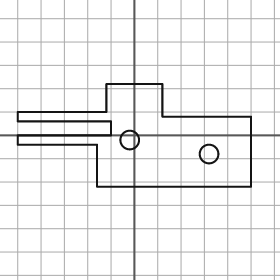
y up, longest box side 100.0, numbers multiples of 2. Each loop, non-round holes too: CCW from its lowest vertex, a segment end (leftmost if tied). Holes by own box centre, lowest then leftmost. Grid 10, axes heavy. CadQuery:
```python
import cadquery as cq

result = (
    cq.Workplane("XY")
    .moveTo(-16.0, -22.0)
    .lineTo(50.0, -22.0)
    .lineTo(50.0, 8.0)
    .lineTo(12.0, 8.0)
    .lineTo(12.0, 22.0)
    .lineTo(-12.0, 22.0)
    .lineTo(-12.0, 10.0)
    .lineTo(-50.0, 10.0)
    .lineTo(-50.0, 6.0)
    .lineTo(-10.0, 6.0)
    .lineTo(-10.0, 0.0)
    .lineTo(-50.0, 0.0)
    .lineTo(-50.0, -4.0)
    .lineTo(-16.0, -4.0)
    .close()
    .moveTo(32.0, -8.0)
    .circle(4.0)
    .moveTo(-2.0, -2.0)
    .circle(4.0)
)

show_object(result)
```